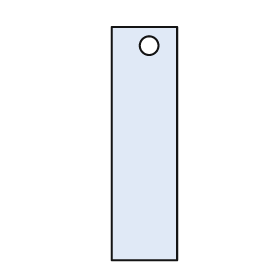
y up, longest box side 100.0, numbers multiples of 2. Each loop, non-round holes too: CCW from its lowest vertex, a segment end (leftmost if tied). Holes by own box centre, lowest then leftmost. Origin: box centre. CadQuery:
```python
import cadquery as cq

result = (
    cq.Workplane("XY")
    .moveTo(-14.0, -50.0)
    .lineTo(14.0, -50.0)
    .lineTo(14.0, 50.0)
    .lineTo(-14.0, 50.0)
    .close()
    .moveTo(2.0, 42.0)
    .circle(4.0)
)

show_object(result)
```